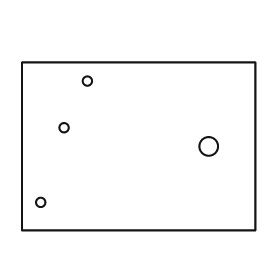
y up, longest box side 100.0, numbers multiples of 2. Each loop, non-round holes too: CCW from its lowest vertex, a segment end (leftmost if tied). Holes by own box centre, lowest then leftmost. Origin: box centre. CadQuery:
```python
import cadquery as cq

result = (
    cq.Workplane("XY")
    .moveTo(-50.0, -36.0)
    .lineTo(50.0, -36.0)
    .lineTo(50.0, 36.0)
    .lineTo(-50.0, 36.0)
    .close()
    .moveTo(-42.0, -24.0)
    .circle(2.0)
    .moveTo(30.0, 0.0)
    .circle(4.0)
    .moveTo(-32.0, 8.0)
    .circle(2.0)
    .moveTo(-22.0, 28.0)
    .circle(2.0)
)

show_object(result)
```